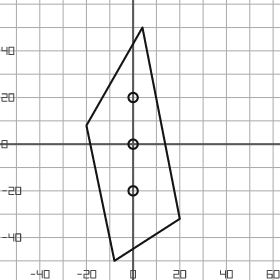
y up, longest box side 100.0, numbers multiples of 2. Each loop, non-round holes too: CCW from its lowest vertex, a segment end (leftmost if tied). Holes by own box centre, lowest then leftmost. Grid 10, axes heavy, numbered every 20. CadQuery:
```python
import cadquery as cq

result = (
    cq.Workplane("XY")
    .moveTo(-8.0, -50.0)
    .lineTo(20.0, -32.0)
    .lineTo(4.0, 50.0)
    .lineTo(-20.0, 8.0)
    .close()
    .moveTo(0.0, -20.0)
    .circle(2.0)
    .moveTo(0.0, 0.0)
    .circle(2.0)
    .moveTo(0.0, 20.0)
    .circle(2.0)
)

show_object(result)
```